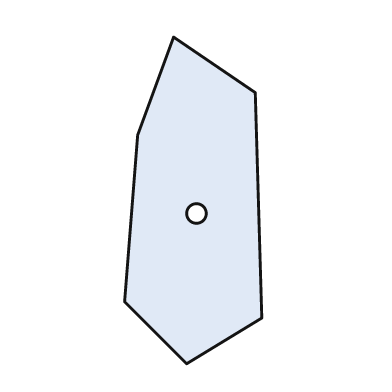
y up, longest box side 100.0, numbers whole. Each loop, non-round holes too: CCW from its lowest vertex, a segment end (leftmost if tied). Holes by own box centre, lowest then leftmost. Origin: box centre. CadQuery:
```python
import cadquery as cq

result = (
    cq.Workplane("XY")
    .moveTo(-2.0, -50.0)
    .lineTo(21.0, -36.0)
    .lineTo(19.0, 33.0)
    .lineTo(-6.0, 50.0)
    .lineTo(-17.0, 20.0)
    .lineTo(-21.0, -31.0)
    .close()
    .moveTo(1.0, -4.0)
    .circle(3.0)
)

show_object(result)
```